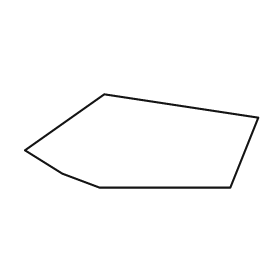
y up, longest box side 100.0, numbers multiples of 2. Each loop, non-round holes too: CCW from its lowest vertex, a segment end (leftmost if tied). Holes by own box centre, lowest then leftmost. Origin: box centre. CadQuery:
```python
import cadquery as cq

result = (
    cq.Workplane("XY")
    .moveTo(-18.0, -20.0)
    .lineTo(38.0, -20.0)
    .lineTo(50.0, 10.0)
    .lineTo(-16.0, 20.0)
    .lineTo(-50.0, -4.0)
    .lineTo(-34.0, -14.0)
    .close()
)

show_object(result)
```